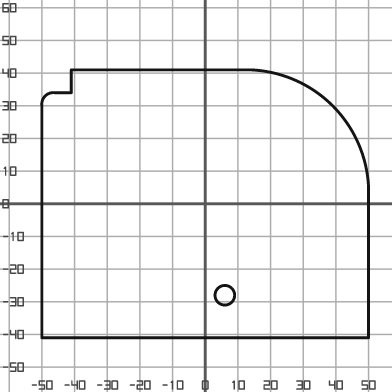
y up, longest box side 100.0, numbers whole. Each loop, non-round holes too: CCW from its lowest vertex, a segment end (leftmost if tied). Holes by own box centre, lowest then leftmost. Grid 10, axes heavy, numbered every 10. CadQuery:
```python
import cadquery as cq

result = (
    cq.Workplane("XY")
    .moveTo(-50.0, -41.0)
    .lineTo(50.0, -41.0)
    .lineTo(50.0, 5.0)
    .threePointArc((39.0, 30.0), (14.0, 41.0))
    .lineTo(-41.0, 41.0)
    .lineTo(-41.0, 34.0)
    .lineTo(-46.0, 34.0)
    .threePointArc((-49.0, 33.0), (-50.0, 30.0))
    .close()
    .moveTo(6.0, -28.0)
    .circle(3.0)
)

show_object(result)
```